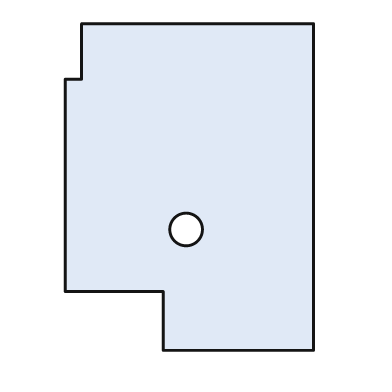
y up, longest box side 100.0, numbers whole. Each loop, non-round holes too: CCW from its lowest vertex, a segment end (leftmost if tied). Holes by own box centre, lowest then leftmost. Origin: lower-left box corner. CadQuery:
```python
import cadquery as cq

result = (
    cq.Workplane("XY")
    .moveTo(30.0, 0.0)
    .lineTo(76.0, 0.0)
    .lineTo(76.0, 100.0)
    .lineTo(5.0, 100.0)
    .lineTo(5.0, 83.0)
    .lineTo(0.0, 83.0)
    .lineTo(0.0, 18.0)
    .lineTo(30.0, 18.0)
    .close()
    .moveTo(37.0, 37.0)
    .circle(5.0)
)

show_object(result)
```